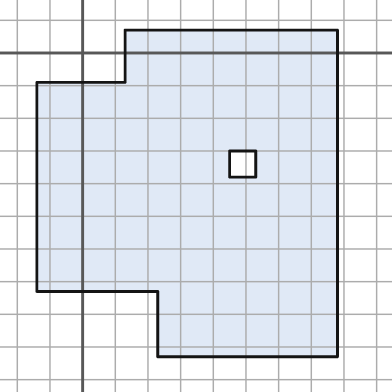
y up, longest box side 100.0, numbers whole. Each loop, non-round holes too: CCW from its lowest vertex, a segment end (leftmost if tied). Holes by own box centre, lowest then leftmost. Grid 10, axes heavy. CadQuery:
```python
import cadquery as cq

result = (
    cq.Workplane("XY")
    .moveTo(23.0, -93.0)
    .lineTo(78.0, -93.0)
    .lineTo(78.0, 7.0)
    .lineTo(13.0, 7.0)
    .lineTo(13.0, -9.0)
    .lineTo(-14.0, -9.0)
    .lineTo(-14.0, -73.0)
    .lineTo(23.0, -73.0)
    .close()
    .moveTo(45.0, -38.0)
    .lineTo(53.0, -38.0)
    .lineTo(53.0, -30.0)
    .lineTo(45.0, -30.0)
    .close()
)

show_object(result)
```